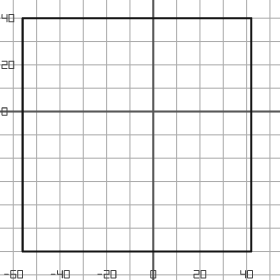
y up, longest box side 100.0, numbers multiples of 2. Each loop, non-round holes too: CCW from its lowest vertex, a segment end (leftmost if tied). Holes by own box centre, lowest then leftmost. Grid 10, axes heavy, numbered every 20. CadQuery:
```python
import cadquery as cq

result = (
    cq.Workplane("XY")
    .moveTo(-56.0, -60.0)
    .lineTo(42.0, -60.0)
    .lineTo(42.0, 40.0)
    .lineTo(-56.0, 40.0)
    .close()
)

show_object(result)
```